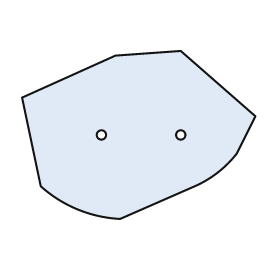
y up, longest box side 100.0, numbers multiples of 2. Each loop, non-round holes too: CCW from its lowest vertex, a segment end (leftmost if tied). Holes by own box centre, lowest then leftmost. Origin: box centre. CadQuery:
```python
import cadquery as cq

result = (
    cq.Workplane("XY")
    .moveTo(-8.0, -36.0)
    .lineTo(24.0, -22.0)
    .threePointArc((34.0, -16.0), (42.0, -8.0))
    .lineTo(50.0, 8.0)
    .lineTo(18.0, 36.0)
    .lineTo(-10.0, 34.0)
    .lineTo(-50.0, 16.0)
    .lineTo(-42.0, -22.0)
    .threePointArc((-26.0, -32.0), (-8.0, -36.0))
    .close()
    .moveTo(-16.0, 0.0)
    .circle(2.0)
    .moveTo(18.0, 0.0)
    .circle(2.0)
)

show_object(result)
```